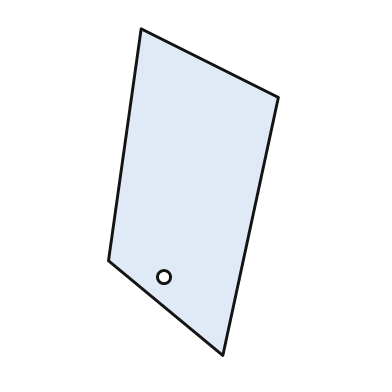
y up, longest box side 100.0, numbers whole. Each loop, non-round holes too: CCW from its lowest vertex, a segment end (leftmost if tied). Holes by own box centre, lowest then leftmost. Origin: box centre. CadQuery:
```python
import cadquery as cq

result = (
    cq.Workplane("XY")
    .moveTo(9.0, -50.0)
    .lineTo(26.0, 29.0)
    .lineTo(-16.0, 50.0)
    .lineTo(-26.0, -21.0)
    .close()
    .moveTo(-9.0, -26.0)
    .circle(2.0)
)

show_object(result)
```